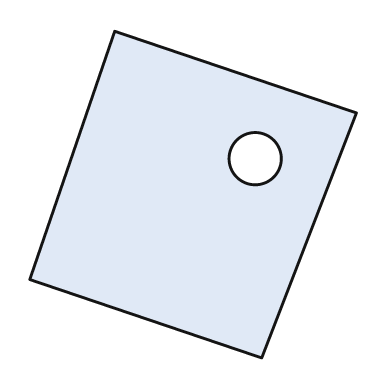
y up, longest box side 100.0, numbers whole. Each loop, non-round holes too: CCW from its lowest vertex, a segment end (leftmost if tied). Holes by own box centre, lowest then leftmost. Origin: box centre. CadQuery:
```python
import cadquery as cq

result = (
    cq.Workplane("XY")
    .moveTo(21.0, -50.0)
    .lineTo(50.0, 25.0)
    .lineTo(-24.0, 50.0)
    .lineTo(-50.0, -26.0)
    .close()
    .moveTo(19.0, 11.0)
    .circle(8.0)
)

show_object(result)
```